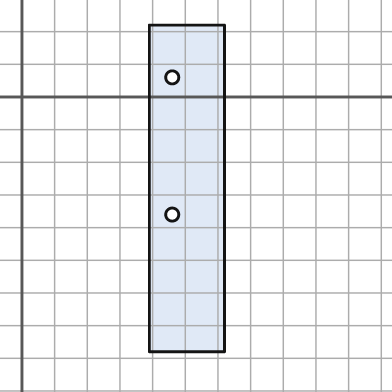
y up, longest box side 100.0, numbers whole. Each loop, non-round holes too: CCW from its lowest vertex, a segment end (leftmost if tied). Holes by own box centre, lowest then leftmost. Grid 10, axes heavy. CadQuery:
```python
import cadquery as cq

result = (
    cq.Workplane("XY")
    .moveTo(39.0, -78.0)
    .lineTo(62.0, -78.0)
    .lineTo(62.0, 22.0)
    .lineTo(39.0, 22.0)
    .close()
    .moveTo(46.0, -36.0)
    .circle(2.0)
    .moveTo(46.0, 6.0)
    .circle(2.0)
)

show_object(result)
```